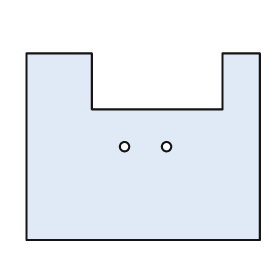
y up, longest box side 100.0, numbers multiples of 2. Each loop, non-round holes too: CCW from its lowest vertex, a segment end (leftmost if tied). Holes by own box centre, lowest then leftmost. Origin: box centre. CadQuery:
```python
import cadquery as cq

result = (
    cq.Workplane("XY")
    .moveTo(-50.0, -40.0)
    .lineTo(50.0, -40.0)
    .lineTo(50.0, 40.0)
    .lineTo(34.0, 40.0)
    .lineTo(34.0, 16.0)
    .lineTo(-22.0, 16.0)
    .lineTo(-22.0, 40.0)
    .lineTo(-50.0, 40.0)
    .close()
    .moveTo(-8.0, 0.0)
    .circle(2.0)
    .moveTo(10.0, 0.0)
    .circle(2.0)
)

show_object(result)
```